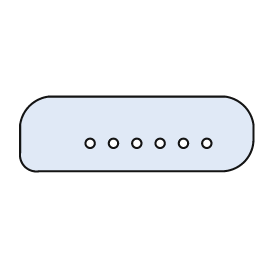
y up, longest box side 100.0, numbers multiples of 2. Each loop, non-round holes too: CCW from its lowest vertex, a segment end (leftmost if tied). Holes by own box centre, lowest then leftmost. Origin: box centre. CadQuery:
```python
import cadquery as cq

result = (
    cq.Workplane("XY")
    .moveTo(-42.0, -16.0)
    .lineTo(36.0, -16.0)
    .threePointArc((46.0, -12.0), (50.0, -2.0))
    .lineTo(50.0, 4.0)
    .threePointArc((46.0, 12.0), (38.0, 16.0))
    .lineTo(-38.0, 16.0)
    .threePointArc((-46.0, 12.0), (-50.0, 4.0))
    .lineTo(-50.0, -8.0)
    .threePointArc((-48.0, -14.0), (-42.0, -16.0))
    .close()
    .moveTo(-20.0, -4.0)
    .circle(2.0)
    .moveTo(-10.0, -4.0)
    .circle(2.0)
    .moveTo(0.0, -4.0)
    .circle(2.0)
    .moveTo(10.0, -4.0)
    .circle(2.0)
    .moveTo(20.0, -4.0)
    .circle(2.0)
    .moveTo(30.0, -4.0)
    .circle(2.0)
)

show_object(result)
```